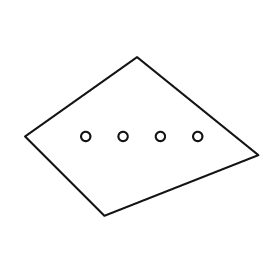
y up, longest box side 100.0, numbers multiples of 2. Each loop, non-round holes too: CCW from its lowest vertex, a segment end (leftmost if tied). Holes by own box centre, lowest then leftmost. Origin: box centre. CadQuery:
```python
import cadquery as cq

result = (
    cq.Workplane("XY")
    .moveTo(-16.0, -34.0)
    .lineTo(50.0, -8.0)
    .lineTo(-2.0, 34.0)
    .lineTo(-50.0, 0.0)
    .close()
    .moveTo(-24.0, 0.0)
    .circle(2.0)
    .moveTo(-8.0, 0.0)
    .circle(2.0)
    .moveTo(8.0, 0.0)
    .circle(2.0)
    .moveTo(24.0, 0.0)
    .circle(2.0)
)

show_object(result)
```